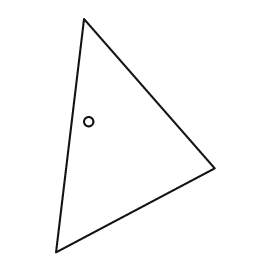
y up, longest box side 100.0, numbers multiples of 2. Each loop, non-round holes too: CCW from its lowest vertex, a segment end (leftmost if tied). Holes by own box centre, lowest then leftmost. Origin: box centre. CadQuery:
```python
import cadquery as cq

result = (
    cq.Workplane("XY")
    .moveTo(-34.0, -50.0)
    .lineTo(34.0, -14.0)
    .lineTo(-22.0, 50.0)
    .close()
    .moveTo(-20.0, 6.0)
    .circle(2.0)
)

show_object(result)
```